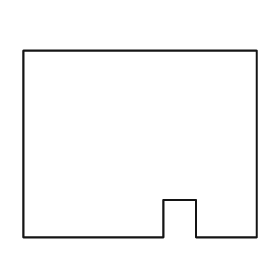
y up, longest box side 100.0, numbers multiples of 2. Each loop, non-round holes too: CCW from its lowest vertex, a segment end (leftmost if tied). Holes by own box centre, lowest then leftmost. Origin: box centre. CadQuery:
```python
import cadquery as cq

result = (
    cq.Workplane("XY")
    .moveTo(-50.0, -40.0)
    .lineTo(10.0, -40.0)
    .lineTo(10.0, -24.0)
    .lineTo(24.0, -24.0)
    .lineTo(24.0, -40.0)
    .lineTo(50.0, -40.0)
    .lineTo(50.0, 40.0)
    .lineTo(-50.0, 40.0)
    .close()
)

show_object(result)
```